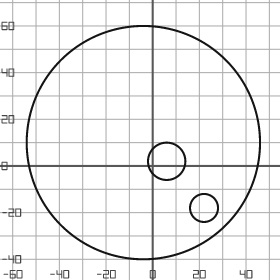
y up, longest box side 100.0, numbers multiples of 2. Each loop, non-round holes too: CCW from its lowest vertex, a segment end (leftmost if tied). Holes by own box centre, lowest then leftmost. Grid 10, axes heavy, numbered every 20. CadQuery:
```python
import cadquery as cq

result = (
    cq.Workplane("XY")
    .moveTo(-4.0, 10.0)
    .circle(50.0)
    .moveTo(22.0, -18.0)
    .circle(6.0)
    .moveTo(6.0, 2.0)
    .circle(8.0)
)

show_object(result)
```